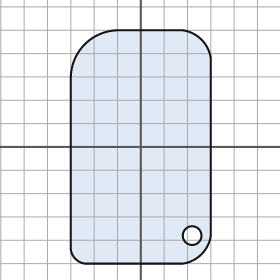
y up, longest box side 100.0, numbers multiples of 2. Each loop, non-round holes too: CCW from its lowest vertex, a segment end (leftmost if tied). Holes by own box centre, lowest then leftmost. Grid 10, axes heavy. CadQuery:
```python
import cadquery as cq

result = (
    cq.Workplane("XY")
    .moveTo(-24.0, -50.0)
    .lineTo(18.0, -50.0)
    .threePointArc((26.0, -46.0), (30.0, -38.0))
    .lineTo(30.0, 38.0)
    .threePointArc((26.0, 46.0), (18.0, 50.0))
    .lineTo(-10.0, 50.0)
    .threePointArc((-24.0, 44.0), (-30.0, 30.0))
    .lineTo(-30.0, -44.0)
    .threePointArc((-28.0, -48.0), (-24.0, -50.0))
    .close()
    .moveTo(22.0, -38.0)
    .circle(4.0)
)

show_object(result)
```